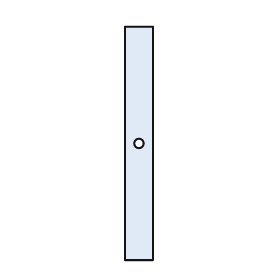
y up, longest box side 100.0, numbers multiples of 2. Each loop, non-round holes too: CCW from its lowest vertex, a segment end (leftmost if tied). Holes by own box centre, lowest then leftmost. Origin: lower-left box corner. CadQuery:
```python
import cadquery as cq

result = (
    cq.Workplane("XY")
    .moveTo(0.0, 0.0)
    .lineTo(12.0, 0.0)
    .lineTo(12.0, 100.0)
    .lineTo(0.0, 100.0)
    .close()
    .moveTo(6.0, 50.0)
    .circle(2.0)
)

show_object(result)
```